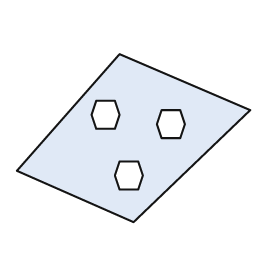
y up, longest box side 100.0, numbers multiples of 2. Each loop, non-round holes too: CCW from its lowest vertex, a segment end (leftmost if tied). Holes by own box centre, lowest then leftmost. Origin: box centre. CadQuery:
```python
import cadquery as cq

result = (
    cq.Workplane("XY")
    .moveTo(0.0, -36.0)
    .lineTo(50.0, 12.0)
    .lineTo(-6.0, 36.0)
    .lineTo(-50.0, -14.0)
    .close()
    .moveTo(-6.0, -22.0)
    .lineTo(2.0, -22.0)
    .lineTo(4.0, -16.0)
    .lineTo(2.0, -10.0)
    .lineTo(-6.0, -10.0)
    .lineTo(-8.0, -16.0)
    .close()
    .moveTo(12.0, 0.0)
    .lineTo(20.0, 0.0)
    .lineTo(22.0, 6.0)
    .lineTo(20.0, 12.0)
    .lineTo(12.0, 12.0)
    .lineTo(10.0, 6.0)
    .close()
    .moveTo(-16.0, 4.0)
    .lineTo(-8.0, 4.0)
    .lineTo(-6.0, 10.0)
    .lineTo(-8.0, 16.0)
    .lineTo(-16.0, 16.0)
    .lineTo(-18.0, 10.0)
    .close()
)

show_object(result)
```